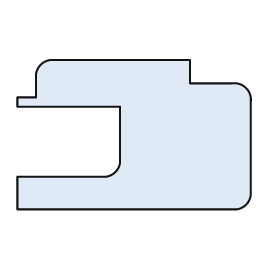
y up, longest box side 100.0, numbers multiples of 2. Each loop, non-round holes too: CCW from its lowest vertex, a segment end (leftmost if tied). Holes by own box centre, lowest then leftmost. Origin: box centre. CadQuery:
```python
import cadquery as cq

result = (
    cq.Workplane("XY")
    .moveTo(-50.0, -32.0)
    .lineTo(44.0, -32.0)
    .threePointArc((48.0, -30.0), (50.0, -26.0))
    .lineTo(50.0, 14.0)
    .threePointArc((48.0, 20.0), (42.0, 22.0))
    .lineTo(24.0, 22.0)
    .lineTo(24.0, 32.0)
    .lineTo(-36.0, 32.0)
    .threePointArc((-40.0, 30.0), (-42.0, 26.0))
    .lineTo(-42.0, 16.0)
    .lineTo(-50.0, 16.0)
    .lineTo(-50.0, 12.0)
    .lineTo(-6.0, 12.0)
    .lineTo(-6.0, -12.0)
    .threePointArc((-8.0, -16.0), (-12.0, -18.0))
    .lineTo(-50.0, -18.0)
    .close()
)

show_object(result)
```